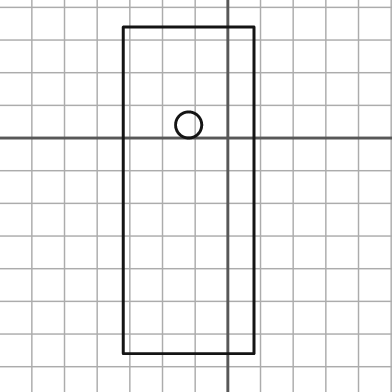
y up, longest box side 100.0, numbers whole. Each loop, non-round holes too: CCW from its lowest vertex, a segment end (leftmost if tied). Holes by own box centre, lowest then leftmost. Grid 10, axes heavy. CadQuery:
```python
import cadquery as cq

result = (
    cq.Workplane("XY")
    .moveTo(-32.0, -66.0)
    .lineTo(8.0, -66.0)
    .lineTo(8.0, 34.0)
    .lineTo(-32.0, 34.0)
    .close()
    .moveTo(-12.0, 4.0)
    .circle(4.0)
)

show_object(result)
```